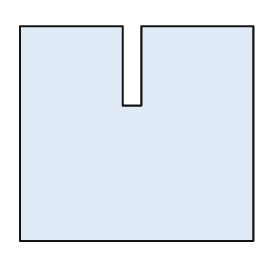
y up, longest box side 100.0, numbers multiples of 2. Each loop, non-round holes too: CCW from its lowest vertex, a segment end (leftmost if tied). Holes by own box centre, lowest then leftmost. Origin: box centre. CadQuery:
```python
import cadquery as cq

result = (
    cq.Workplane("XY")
    .moveTo(-50.0, -46.0)
    .lineTo(50.0, -46.0)
    .lineTo(50.0, 46.0)
    .lineTo(2.0, 46.0)
    .lineTo(2.0, 12.0)
    .lineTo(-6.0, 12.0)
    .lineTo(-6.0, 46.0)
    .lineTo(-50.0, 46.0)
    .close()
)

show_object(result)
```